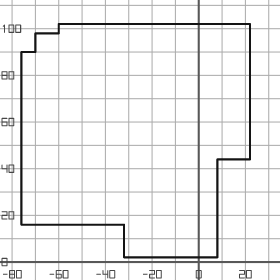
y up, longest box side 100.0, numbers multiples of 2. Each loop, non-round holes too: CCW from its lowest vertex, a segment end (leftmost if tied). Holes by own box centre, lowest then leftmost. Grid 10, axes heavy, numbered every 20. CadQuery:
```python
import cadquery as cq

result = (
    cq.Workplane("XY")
    .moveTo(-32.0, 2.0)
    .lineTo(8.0, 2.0)
    .lineTo(8.0, 44.0)
    .lineTo(22.0, 44.0)
    .lineTo(22.0, 102.0)
    .lineTo(-60.0, 102.0)
    .lineTo(-60.0, 98.0)
    .lineTo(-70.0, 98.0)
    .lineTo(-70.0, 90.0)
    .lineTo(-76.0, 90.0)
    .lineTo(-76.0, 16.0)
    .lineTo(-32.0, 16.0)
    .close()
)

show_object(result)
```